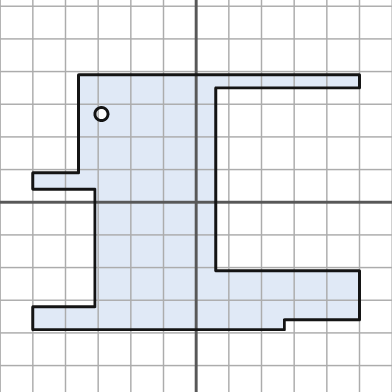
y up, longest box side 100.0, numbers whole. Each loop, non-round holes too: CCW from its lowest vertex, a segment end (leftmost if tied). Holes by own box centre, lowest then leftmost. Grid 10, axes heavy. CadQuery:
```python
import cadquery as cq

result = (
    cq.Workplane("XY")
    .moveTo(-50.0, -39.0)
    .lineTo(27.0, -39.0)
    .lineTo(27.0, -36.0)
    .lineTo(50.0, -36.0)
    .lineTo(50.0, -21.0)
    .lineTo(6.0, -21.0)
    .lineTo(6.0, 35.0)
    .lineTo(50.0, 35.0)
    .lineTo(50.0, 39.0)
    .lineTo(-36.0, 39.0)
    .lineTo(-36.0, 9.0)
    .lineTo(-50.0, 9.0)
    .lineTo(-50.0, 4.0)
    .lineTo(-31.0, 4.0)
    .lineTo(-31.0, -32.0)
    .lineTo(-50.0, -32.0)
    .close()
    .moveTo(-29.0, 27.0)
    .circle(2.0)
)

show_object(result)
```